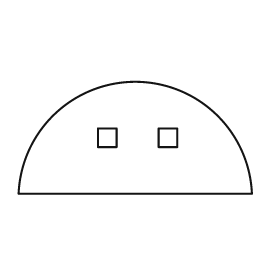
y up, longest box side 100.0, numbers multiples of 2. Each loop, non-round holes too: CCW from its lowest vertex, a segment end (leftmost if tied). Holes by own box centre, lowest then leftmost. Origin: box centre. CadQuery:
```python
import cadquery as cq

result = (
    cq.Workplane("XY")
    .moveTo(-50.0, -24.0)
    .lineTo(50.0, -24.0)
    .threePointArc((0.0, 24.0), (-50.0, -24.0))
    .close()
    .moveTo(-16.0, -4.0)
    .lineTo(-8.0, -4.0)
    .lineTo(-8.0, 4.0)
    .lineTo(-16.0, 4.0)
    .close()
    .moveTo(10.0, -4.0)
    .lineTo(18.0, -4.0)
    .lineTo(18.0, 4.0)
    .lineTo(10.0, 4.0)
    .close()
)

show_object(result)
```